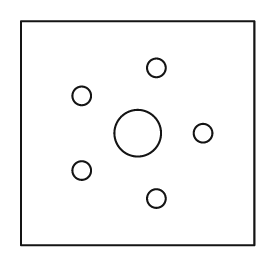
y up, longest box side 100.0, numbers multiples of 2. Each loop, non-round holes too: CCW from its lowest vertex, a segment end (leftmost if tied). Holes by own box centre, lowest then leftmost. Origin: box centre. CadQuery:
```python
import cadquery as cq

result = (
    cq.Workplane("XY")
    .moveTo(-50.0, -48.0)
    .lineTo(50.0, -48.0)
    .lineTo(50.0, 48.0)
    .lineTo(-50.0, 48.0)
    .close()
    .moveTo(8.0, -28.0)
    .circle(4.0)
    .moveTo(-24.0, -16.0)
    .circle(4.0)
    .moveTo(0.0, 0.0)
    .circle(10.0)
    .moveTo(28.0, 0.0)
    .circle(4.0)
    .moveTo(-24.0, 16.0)
    .circle(4.0)
    .moveTo(8.0, 28.0)
    .circle(4.0)
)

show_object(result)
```